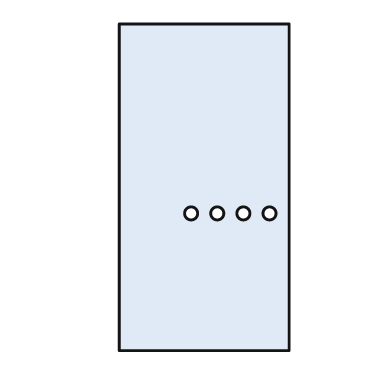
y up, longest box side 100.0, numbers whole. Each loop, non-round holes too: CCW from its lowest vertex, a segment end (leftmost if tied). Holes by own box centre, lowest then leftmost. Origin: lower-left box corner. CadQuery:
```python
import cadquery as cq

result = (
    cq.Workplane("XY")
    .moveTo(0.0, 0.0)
    .lineTo(52.0, 0.0)
    .lineTo(52.0, 100.0)
    .lineTo(0.0, 100.0)
    .close()
    .moveTo(22.0, 42.0)
    .circle(2.0)
    .moveTo(30.0, 42.0)
    .circle(2.0)
    .moveTo(38.0, 42.0)
    .circle(2.0)
    .moveTo(46.0, 42.0)
    .circle(2.0)
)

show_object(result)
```